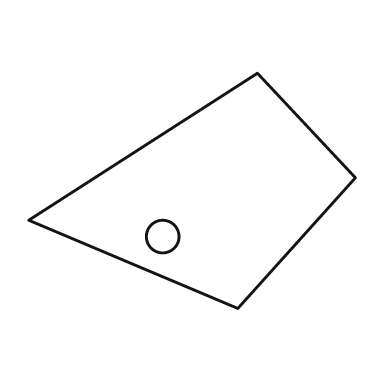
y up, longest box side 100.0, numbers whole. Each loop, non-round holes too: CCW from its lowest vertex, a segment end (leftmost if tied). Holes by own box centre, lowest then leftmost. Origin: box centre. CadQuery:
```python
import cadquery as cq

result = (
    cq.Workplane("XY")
    .moveTo(14.0, -36.0)
    .lineTo(50.0, 4.0)
    .lineTo(20.0, 36.0)
    .lineTo(-50.0, -9.0)
    .close()
    .moveTo(-9.0, -14.0)
    .circle(5.0)
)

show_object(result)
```